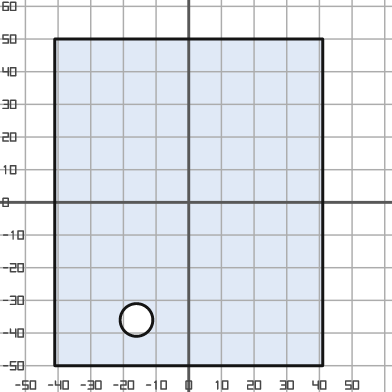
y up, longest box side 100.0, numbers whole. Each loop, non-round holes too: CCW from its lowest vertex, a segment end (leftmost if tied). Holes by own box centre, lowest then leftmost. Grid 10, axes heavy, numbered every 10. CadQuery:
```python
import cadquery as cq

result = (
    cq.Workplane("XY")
    .moveTo(-41.0, -50.0)
    .lineTo(41.0, -50.0)
    .lineTo(41.0, 50.0)
    .lineTo(-41.0, 50.0)
    .close()
    .moveTo(-16.0, -36.0)
    .circle(5.0)
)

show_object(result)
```